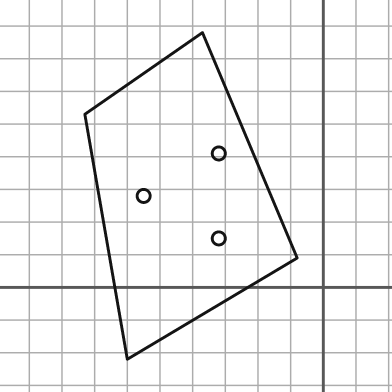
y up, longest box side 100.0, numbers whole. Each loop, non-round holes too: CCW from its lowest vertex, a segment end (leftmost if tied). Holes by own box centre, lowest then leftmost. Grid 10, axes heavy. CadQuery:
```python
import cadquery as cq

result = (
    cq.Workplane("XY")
    .moveTo(-60.0, -22.0)
    .lineTo(-8.0, 9.0)
    .lineTo(-37.0, 78.0)
    .lineTo(-73.0, 53.0)
    .close()
    .moveTo(-32.0, 15.0)
    .circle(2.0)
    .moveTo(-55.0, 28.0)
    .circle(2.0)
    .moveTo(-32.0, 41.0)
    .circle(2.0)
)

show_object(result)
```